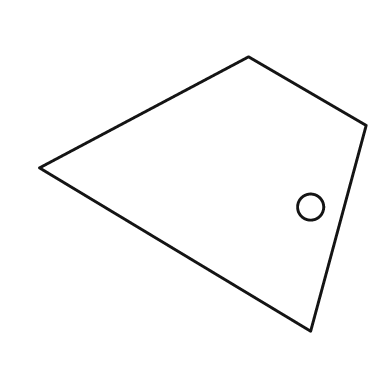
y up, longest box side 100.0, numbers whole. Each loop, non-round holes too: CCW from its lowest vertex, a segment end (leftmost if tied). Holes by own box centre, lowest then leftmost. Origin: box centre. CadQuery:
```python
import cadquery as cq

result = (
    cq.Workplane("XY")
    .moveTo(33.0, -42.0)
    .lineTo(50.0, 21.0)
    .lineTo(14.0, 42.0)
    .lineTo(-50.0, 8.0)
    .close()
    .moveTo(33.0, -4.0)
    .circle(4.0)
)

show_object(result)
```